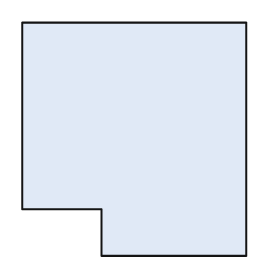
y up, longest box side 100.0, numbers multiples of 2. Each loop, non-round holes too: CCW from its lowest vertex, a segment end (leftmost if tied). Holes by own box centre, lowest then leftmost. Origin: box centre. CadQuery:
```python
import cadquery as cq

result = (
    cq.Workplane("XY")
    .moveTo(-14.0, -50.0)
    .lineTo(48.0, -50.0)
    .lineTo(48.0, 50.0)
    .lineTo(-48.0, 50.0)
    .lineTo(-48.0, -30.0)
    .lineTo(-14.0, -30.0)
    .close()
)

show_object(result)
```